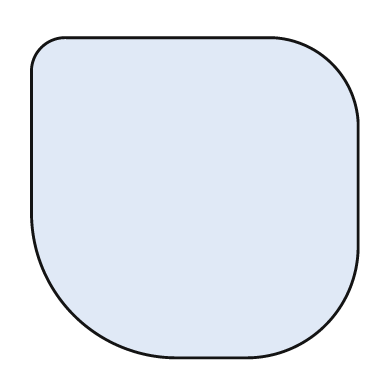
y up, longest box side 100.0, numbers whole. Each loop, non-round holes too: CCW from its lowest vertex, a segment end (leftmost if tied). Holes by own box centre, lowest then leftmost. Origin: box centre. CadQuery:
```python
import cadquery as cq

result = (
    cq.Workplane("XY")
    .moveTo(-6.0, -49.0)
    .lineTo(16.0, -49.0)
    .threePointArc((40.0, -39.0), (50.0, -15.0))
    .lineTo(50.0, 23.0)
    .threePointArc((42.0, 41.0), (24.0, 49.0))
    .lineTo(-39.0, 49.0)
    .threePointArc((-47.0, 46.0), (-50.0, 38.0))
    .lineTo(-50.0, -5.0)
    .threePointArc((-37.0, -36.0), (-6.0, -49.0))
    .close()
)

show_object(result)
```